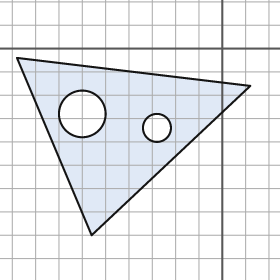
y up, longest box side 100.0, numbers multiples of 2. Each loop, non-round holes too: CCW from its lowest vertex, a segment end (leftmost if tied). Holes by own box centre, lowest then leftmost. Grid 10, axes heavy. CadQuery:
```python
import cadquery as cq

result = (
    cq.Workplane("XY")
    .moveTo(-56.0, -80.0)
    .lineTo(12.0, -16.0)
    .lineTo(-88.0, -4.0)
    .close()
    .moveTo(-28.0, -34.0)
    .circle(6.0)
    .moveTo(-60.0, -28.0)
    .circle(10.0)
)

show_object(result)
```